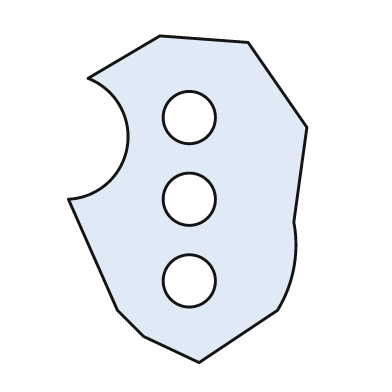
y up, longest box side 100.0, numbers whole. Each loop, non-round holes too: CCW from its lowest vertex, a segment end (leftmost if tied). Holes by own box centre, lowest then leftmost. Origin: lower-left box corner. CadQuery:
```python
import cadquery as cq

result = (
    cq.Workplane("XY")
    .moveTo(40.0, 0.0)
    .lineTo(64.0, 16.0)
    .threePointArc((69.0, 29.0), (69.0, 43.0))
    .lineTo(73.0, 72.0)
    .lineTo(55.0, 98.0)
    .lineTo(28.0, 100.0)
    .lineTo(6.0, 87.0)
    .threePointArc((18.0, 66.0), (0.0, 50.0))
    .lineTo(15.0, 16.0)
    .lineTo(23.0, 8.0)
    .close()
    .moveTo(37.0, 25.0)
    .circle(8.0)
    .moveTo(37.0, 50.0)
    .circle(8.0)
    .moveTo(37.0, 75.0)
    .circle(8.0)
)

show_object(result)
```